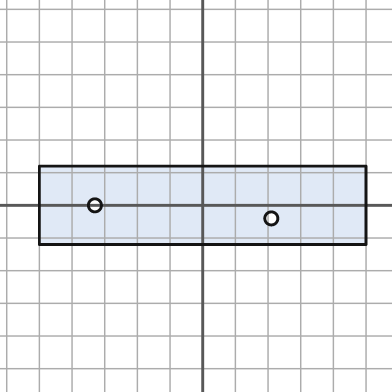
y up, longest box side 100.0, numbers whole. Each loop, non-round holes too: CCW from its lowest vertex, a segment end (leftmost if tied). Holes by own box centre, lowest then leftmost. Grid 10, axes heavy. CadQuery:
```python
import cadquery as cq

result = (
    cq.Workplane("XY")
    .moveTo(-50.0, -12.0)
    .lineTo(50.0, -12.0)
    .lineTo(50.0, 12.0)
    .lineTo(-50.0, 12.0)
    .close()
    .moveTo(21.0, -4.0)
    .circle(2.0)
    .moveTo(-33.0, 0.0)
    .circle(2.0)
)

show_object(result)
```